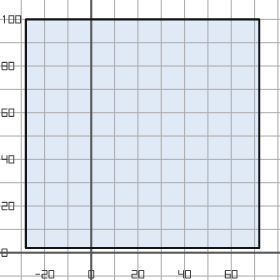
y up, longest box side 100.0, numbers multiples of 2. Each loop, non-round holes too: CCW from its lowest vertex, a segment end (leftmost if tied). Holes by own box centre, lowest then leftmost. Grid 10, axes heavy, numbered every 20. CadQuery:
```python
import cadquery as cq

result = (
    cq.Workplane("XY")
    .moveTo(-28.0, 2.0)
    .lineTo(72.0, 2.0)
    .lineTo(72.0, 100.0)
    .lineTo(-28.0, 100.0)
    .close()
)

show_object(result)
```